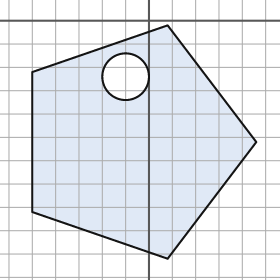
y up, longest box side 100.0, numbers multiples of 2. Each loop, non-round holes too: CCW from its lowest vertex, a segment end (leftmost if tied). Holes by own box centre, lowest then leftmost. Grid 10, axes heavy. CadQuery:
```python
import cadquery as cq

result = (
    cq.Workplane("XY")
    .moveTo(8.0, -102.0)
    .lineTo(46.0, -52.0)
    .lineTo(8.0, -2.0)
    .lineTo(-50.0, -22.0)
    .lineTo(-50.0, -82.0)
    .close()
    .moveTo(-10.0, -24.0)
    .circle(10.0)
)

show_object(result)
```